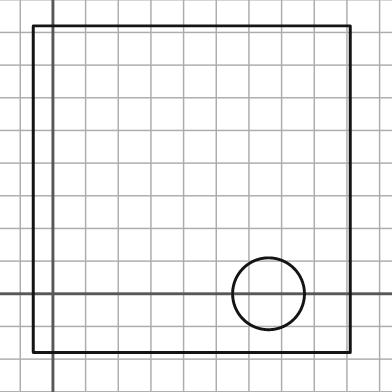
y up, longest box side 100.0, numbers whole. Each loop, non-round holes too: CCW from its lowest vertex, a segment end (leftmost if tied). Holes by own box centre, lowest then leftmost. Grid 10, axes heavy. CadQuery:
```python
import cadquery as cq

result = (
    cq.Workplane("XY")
    .moveTo(-6.0, -18.0)
    .lineTo(91.0, -18.0)
    .lineTo(91.0, 82.0)
    .lineTo(-6.0, 82.0)
    .close()
    .moveTo(66.0, 0.0)
    .circle(11.0)
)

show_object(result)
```